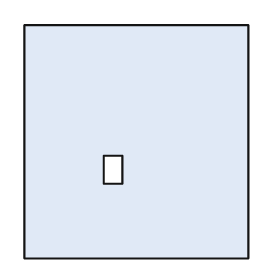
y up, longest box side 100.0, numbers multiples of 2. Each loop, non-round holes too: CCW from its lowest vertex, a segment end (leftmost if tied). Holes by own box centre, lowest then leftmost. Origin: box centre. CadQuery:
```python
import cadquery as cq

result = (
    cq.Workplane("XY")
    .moveTo(-48.0, -50.0)
    .lineTo(48.0, -50.0)
    .lineTo(48.0, 50.0)
    .lineTo(-48.0, 50.0)
    .close()
    .moveTo(-14.0, -18.0)
    .lineTo(-6.0, -18.0)
    .lineTo(-6.0, -6.0)
    .lineTo(-14.0, -6.0)
    .close()
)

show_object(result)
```